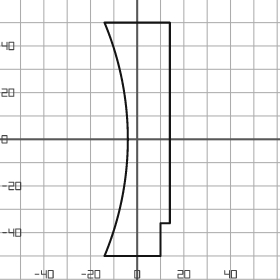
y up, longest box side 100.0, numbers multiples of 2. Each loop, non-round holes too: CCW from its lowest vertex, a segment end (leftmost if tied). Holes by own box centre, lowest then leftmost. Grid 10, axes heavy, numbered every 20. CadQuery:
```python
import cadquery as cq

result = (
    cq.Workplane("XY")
    .moveTo(-14.0, -50.0)
    .lineTo(10.0, -50.0)
    .lineTo(10.0, -36.0)
    .lineTo(14.0, -36.0)
    .lineTo(14.0, 50.0)
    .lineTo(-14.0, 50.0)
    .threePointArc((-4.0, 0.0), (-14.0, -50.0))
    .close()
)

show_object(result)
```